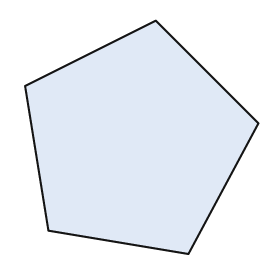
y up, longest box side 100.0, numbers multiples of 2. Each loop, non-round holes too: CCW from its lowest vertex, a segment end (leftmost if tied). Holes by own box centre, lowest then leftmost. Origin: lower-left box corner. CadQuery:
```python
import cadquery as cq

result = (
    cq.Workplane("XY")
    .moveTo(70.0, 0.0)
    .lineTo(100.0, 56.0)
    .lineTo(56.0, 100.0)
    .lineTo(0.0, 72.0)
    .lineTo(10.0, 10.0)
    .close()
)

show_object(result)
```